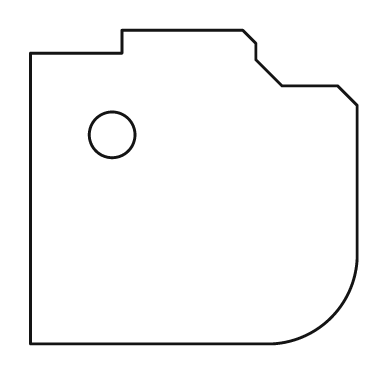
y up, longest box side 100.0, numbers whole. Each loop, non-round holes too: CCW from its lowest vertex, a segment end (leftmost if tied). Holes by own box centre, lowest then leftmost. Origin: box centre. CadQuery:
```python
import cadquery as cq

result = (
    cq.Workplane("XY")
    .moveTo(-50.0, -48.0)
    .lineTo(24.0, -48.0)
    .threePointArc((42.0, -40.0), (50.0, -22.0))
    .lineTo(50.0, 25.0)
    .lineTo(44.0, 31.0)
    .lineTo(27.0, 31.0)
    .lineTo(19.0, 39.0)
    .lineTo(19.0, 44.0)
    .lineTo(15.0, 48.0)
    .lineTo(-22.0, 48.0)
    .lineTo(-22.0, 41.0)
    .lineTo(-50.0, 41.0)
    .close()
    .moveTo(-25.0, 16.0)
    .circle(7.0)
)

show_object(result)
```